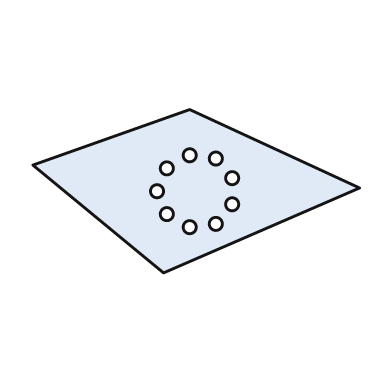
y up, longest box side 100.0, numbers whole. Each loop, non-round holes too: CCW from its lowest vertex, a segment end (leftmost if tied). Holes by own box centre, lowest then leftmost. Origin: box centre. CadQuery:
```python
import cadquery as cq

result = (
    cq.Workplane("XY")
    .moveTo(-10.0, -25.0)
    .lineTo(50.0, 1.0)
    .lineTo(-2.0, 25.0)
    .lineTo(-50.0, 8.0)
    .close()
    .moveTo(-2.0, -11.0)
    .circle(2.0)
    .moveTo(6.0, -10.0)
    .circle(2.0)
    .moveTo(-9.0, -7.0)
    .circle(2.0)
    .moveTo(11.0, -4.0)
    .circle(2.0)
    .moveTo(-12.0, 0.0)
    .circle(2.0)
    .moveTo(11.0, 4.0)
    .circle(2.0)
    .moveTo(-9.0, 7.0)
    .circle(2.0)
    .moveTo(6.0, 10.0)
    .circle(2.0)
    .moveTo(-2.0, 11.0)
    .circle(2.0)
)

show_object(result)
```